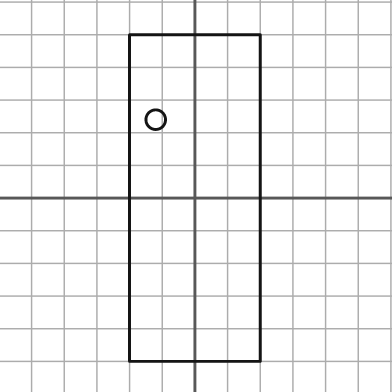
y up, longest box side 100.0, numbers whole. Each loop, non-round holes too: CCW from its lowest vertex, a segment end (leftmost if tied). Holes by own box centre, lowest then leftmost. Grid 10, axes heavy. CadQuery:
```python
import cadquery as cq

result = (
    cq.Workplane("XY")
    .moveTo(-20.0, -50.0)
    .lineTo(20.0, -50.0)
    .lineTo(20.0, 50.0)
    .lineTo(-20.0, 50.0)
    .close()
    .moveTo(-12.0, 24.0)
    .circle(3.0)
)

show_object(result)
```